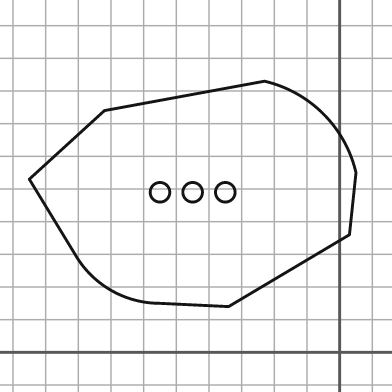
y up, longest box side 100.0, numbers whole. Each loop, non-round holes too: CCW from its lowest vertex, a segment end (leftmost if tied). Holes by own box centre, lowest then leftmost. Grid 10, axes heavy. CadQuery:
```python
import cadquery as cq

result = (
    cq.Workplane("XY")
    .moveTo(-34.0, 14.0)
    .lineTo(3.0, 36.0)
    .lineTo(5.0, 55.0)
    .threePointArc((-5.0, 73.0), (-23.0, 83.0))
    .lineTo(-72.0, 74.0)
    .lineTo(-95.0, 53.0)
    .lineTo(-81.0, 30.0)
    .threePointArc((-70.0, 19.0), (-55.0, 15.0))
    .close()
    .moveTo(-55.0, 49.0)
    .circle(3.0)
    .moveTo(-45.0, 49.0)
    .circle(3.0)
    .moveTo(-35.0, 49.0)
    .circle(3.0)
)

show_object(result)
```